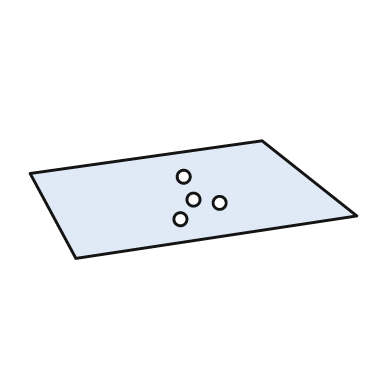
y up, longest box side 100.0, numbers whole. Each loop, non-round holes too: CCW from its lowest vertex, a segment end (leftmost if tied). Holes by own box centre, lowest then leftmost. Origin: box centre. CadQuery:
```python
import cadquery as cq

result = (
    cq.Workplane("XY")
    .moveTo(-36.0, -18.0)
    .lineTo(50.0, -5.0)
    .lineTo(21.0, 18.0)
    .lineTo(-50.0, 8.0)
    .close()
    .moveTo(-4.0, -6.0)
    .circle(2.0)
    .moveTo(8.0, -1.0)
    .circle(2.0)
    .moveTo(0.0, 0.0)
    .circle(2.0)
    .moveTo(-3.0, 7.0)
    .circle(2.0)
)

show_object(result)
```